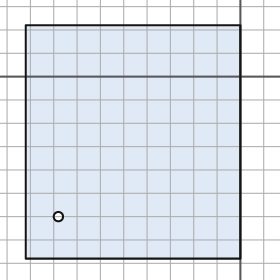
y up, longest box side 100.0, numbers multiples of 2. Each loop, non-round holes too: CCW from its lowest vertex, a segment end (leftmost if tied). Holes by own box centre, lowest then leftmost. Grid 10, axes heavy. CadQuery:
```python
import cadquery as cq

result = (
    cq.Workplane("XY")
    .moveTo(-92.0, -78.0)
    .lineTo(0.0, -78.0)
    .lineTo(0.0, 22.0)
    .lineTo(-92.0, 22.0)
    .close()
    .moveTo(-78.0, -60.0)
    .circle(2.0)
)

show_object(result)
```